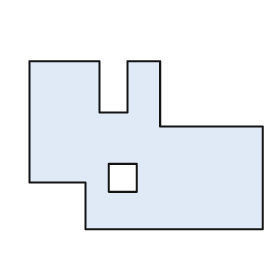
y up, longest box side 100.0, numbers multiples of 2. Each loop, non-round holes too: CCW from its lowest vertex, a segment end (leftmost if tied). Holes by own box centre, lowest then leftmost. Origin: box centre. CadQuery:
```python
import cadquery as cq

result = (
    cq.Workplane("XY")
    .moveTo(-26.0, -36.0)
    .lineTo(50.0, -36.0)
    .lineTo(50.0, 8.0)
    .lineTo(6.0, 8.0)
    .lineTo(6.0, 36.0)
    .lineTo(-8.0, 36.0)
    .lineTo(-8.0, 14.0)
    .lineTo(-20.0, 14.0)
    .lineTo(-20.0, 36.0)
    .lineTo(-50.0, 36.0)
    .lineTo(-50.0, -16.0)
    .lineTo(-26.0, -16.0)
    .close()
    .moveTo(-16.0, -20.0)
    .lineTo(-4.0, -20.0)
    .lineTo(-4.0, -8.0)
    .lineTo(-16.0, -8.0)
    .close()
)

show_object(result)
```